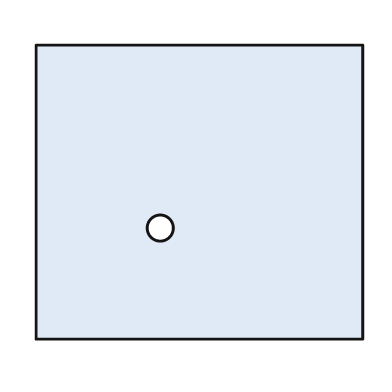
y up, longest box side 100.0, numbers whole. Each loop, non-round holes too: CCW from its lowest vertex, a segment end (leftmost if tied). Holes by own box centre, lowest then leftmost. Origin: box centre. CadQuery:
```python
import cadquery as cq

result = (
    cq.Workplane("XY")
    .moveTo(-50.0, -45.0)
    .lineTo(50.0, -45.0)
    .lineTo(50.0, 45.0)
    .lineTo(-50.0, 45.0)
    .close()
    .moveTo(-12.0, -11.0)
    .circle(4.0)
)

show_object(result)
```